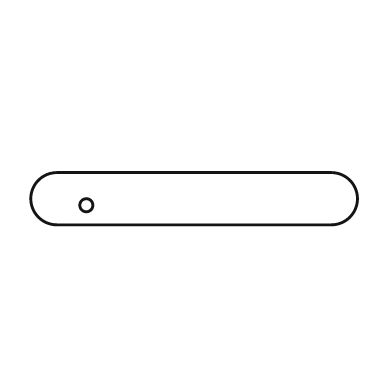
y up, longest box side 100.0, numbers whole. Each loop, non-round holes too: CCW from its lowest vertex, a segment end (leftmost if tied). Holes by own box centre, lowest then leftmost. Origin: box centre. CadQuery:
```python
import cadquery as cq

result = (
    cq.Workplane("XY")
    .moveTo(-42.0, -8.0)
    .lineTo(42.0, -8.0)
    .threePointArc((50.0, 0.0), (42.0, 8.0))
    .lineTo(-42.0, 8.0)
    .threePointArc((-50.0, 0.0), (-42.0, -8.0))
    .close()
    .moveTo(-33.0, -2.0)
    .circle(2.0)
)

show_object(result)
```